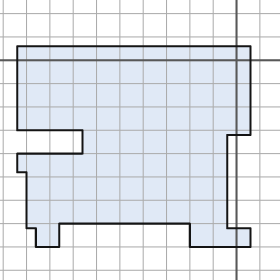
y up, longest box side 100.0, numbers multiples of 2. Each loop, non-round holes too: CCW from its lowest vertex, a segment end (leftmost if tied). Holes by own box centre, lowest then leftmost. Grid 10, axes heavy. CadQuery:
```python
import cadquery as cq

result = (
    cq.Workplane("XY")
    .moveTo(-86.0, -80.0)
    .lineTo(-76.0, -80.0)
    .lineTo(-76.0, -70.0)
    .lineTo(-20.0, -70.0)
    .lineTo(-20.0, -80.0)
    .lineTo(6.0, -80.0)
    .lineTo(6.0, -72.0)
    .lineTo(-4.0, -72.0)
    .lineTo(-4.0, -32.0)
    .lineTo(6.0, -32.0)
    .lineTo(6.0, 6.0)
    .lineTo(-94.0, 6.0)
    .lineTo(-94.0, -30.0)
    .lineTo(-66.0, -30.0)
    .lineTo(-66.0, -40.0)
    .lineTo(-94.0, -40.0)
    .lineTo(-94.0, -48.0)
    .lineTo(-90.0, -48.0)
    .lineTo(-90.0, -72.0)
    .lineTo(-86.0, -72.0)
    .close()
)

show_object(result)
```